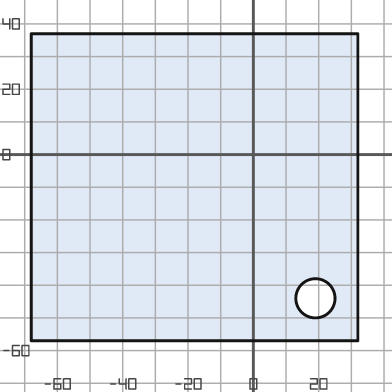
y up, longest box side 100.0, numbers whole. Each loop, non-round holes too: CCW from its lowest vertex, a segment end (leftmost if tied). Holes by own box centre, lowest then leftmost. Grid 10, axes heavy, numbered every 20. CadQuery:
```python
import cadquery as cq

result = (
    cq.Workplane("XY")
    .moveTo(-68.0, -57.0)
    .lineTo(32.0, -57.0)
    .lineTo(32.0, 37.0)
    .lineTo(-68.0, 37.0)
    .close()
    .moveTo(19.0, -44.0)
    .circle(6.0)
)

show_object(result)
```